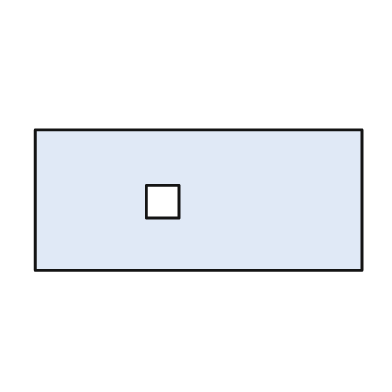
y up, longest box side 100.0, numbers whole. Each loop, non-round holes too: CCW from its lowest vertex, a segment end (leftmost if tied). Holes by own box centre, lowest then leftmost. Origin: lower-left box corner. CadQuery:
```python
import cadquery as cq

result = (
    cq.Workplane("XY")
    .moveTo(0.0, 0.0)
    .lineTo(100.0, 0.0)
    .lineTo(100.0, 43.0)
    .lineTo(0.0, 43.0)
    .close()
    .moveTo(34.0, 16.0)
    .lineTo(44.0, 16.0)
    .lineTo(44.0, 26.0)
    .lineTo(34.0, 26.0)
    .close()
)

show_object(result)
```